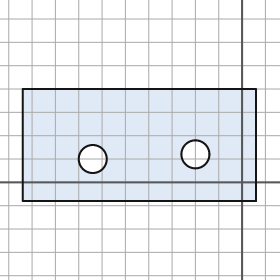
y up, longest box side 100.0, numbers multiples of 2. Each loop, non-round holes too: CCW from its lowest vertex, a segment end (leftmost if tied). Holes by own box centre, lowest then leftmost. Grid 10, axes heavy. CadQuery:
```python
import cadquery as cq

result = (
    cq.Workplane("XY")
    .moveTo(-94.0, -8.0)
    .lineTo(6.0, -8.0)
    .lineTo(6.0, 40.0)
    .lineTo(-94.0, 40.0)
    .close()
    .moveTo(-64.0, 10.0)
    .circle(6.0)
    .moveTo(-20.0, 12.0)
    .circle(6.0)
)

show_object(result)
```